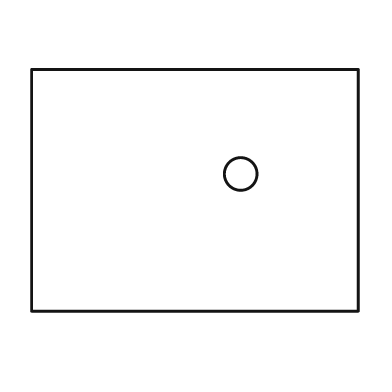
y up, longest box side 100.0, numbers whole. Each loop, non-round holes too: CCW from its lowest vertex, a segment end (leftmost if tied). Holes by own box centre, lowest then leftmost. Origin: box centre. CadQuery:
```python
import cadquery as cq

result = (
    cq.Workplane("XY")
    .moveTo(-50.0, -37.0)
    .lineTo(50.0, -37.0)
    .lineTo(50.0, 37.0)
    .lineTo(-50.0, 37.0)
    .close()
    .moveTo(14.0, 5.0)
    .circle(5.0)
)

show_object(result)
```